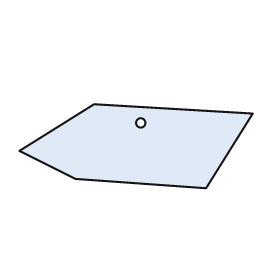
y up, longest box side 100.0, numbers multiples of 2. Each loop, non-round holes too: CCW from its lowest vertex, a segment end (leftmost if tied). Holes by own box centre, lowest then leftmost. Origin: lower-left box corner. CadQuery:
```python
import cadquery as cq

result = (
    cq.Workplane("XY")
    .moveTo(80.0, 0.0)
    .lineTo(100.0, 32.0)
    .lineTo(32.0, 36.0)
    .lineTo(0.0, 16.0)
    .lineTo(24.0, 4.0)
    .close()
    .moveTo(52.0, 28.0)
    .circle(2.0)
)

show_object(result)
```